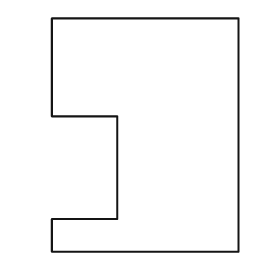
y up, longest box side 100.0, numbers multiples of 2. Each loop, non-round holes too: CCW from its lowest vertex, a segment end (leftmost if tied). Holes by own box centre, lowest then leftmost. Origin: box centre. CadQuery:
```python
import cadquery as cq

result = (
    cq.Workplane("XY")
    .moveTo(-40.0, -50.0)
    .lineTo(40.0, -50.0)
    .lineTo(40.0, 50.0)
    .lineTo(-40.0, 50.0)
    .lineTo(-40.0, 8.0)
    .lineTo(-12.0, 8.0)
    .lineTo(-12.0, -36.0)
    .lineTo(-40.0, -36.0)
    .close()
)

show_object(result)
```